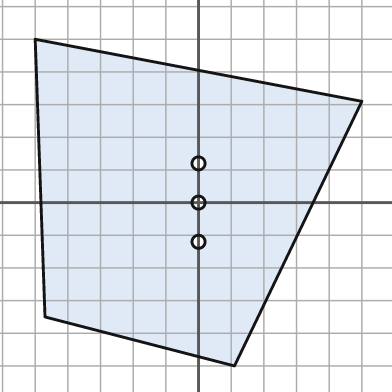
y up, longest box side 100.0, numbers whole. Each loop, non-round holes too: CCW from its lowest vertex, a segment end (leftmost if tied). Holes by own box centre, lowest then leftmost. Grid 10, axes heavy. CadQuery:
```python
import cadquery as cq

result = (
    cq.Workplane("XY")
    .moveTo(11.0, -50.0)
    .lineTo(50.0, 31.0)
    .lineTo(-50.0, 50.0)
    .lineTo(-47.0, -35.0)
    .close()
    .moveTo(0.0, -12.0)
    .circle(2.0)
    .moveTo(0.0, 0.0)
    .circle(2.0)
    .moveTo(0.0, 12.0)
    .circle(2.0)
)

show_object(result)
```